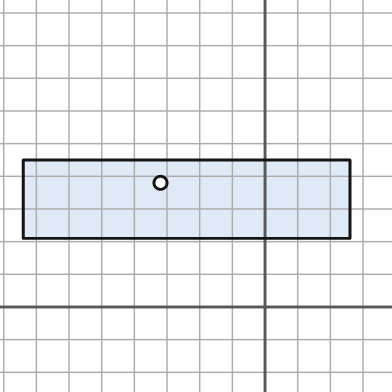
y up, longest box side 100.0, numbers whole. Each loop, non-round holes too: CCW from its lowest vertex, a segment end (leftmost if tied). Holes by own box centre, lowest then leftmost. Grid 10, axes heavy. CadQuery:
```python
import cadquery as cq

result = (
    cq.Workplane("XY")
    .moveTo(-74.0, 21.0)
    .lineTo(26.0, 21.0)
    .lineTo(26.0, 45.0)
    .lineTo(-74.0, 45.0)
    .close()
    .moveTo(-32.0, 38.0)
    .circle(2.0)
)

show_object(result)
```